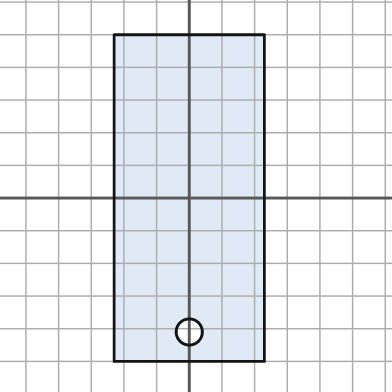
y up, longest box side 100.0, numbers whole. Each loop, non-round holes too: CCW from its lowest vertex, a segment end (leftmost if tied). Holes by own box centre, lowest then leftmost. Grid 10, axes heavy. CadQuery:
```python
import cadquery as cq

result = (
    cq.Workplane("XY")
    .moveTo(-23.0, -50.0)
    .lineTo(23.0, -50.0)
    .lineTo(23.0, 50.0)
    .lineTo(-23.0, 50.0)
    .close()
    .moveTo(0.0, -41.0)
    .circle(4.0)
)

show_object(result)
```